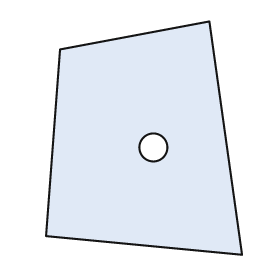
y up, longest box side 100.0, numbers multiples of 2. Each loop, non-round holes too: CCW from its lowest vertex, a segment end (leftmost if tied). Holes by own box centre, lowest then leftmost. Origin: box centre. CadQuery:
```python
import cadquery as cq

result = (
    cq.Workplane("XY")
    .moveTo(42.0, -50.0)
    .lineTo(28.0, 50.0)
    .lineTo(-36.0, 38.0)
    .lineTo(-42.0, -42.0)
    .close()
    .moveTo(4.0, -4.0)
    .circle(6.0)
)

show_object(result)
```